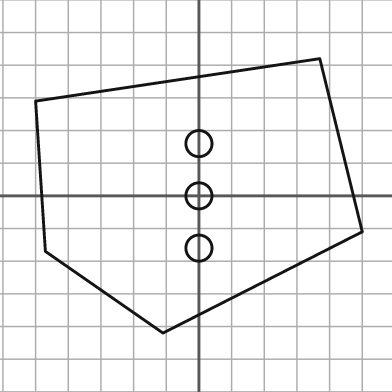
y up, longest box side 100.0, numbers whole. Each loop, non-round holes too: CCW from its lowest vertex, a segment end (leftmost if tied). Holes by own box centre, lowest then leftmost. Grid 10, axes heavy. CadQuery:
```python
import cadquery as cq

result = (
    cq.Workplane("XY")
    .moveTo(-11.0, -42.0)
    .lineTo(50.0, -11.0)
    .lineTo(37.0, 42.0)
    .lineTo(-50.0, 29.0)
    .lineTo(-47.0, -17.0)
    .close()
    .moveTo(0.0, -16.0)
    .circle(4.0)
    .moveTo(0.0, 0.0)
    .circle(4.0)
    .moveTo(0.0, 16.0)
    .circle(4.0)
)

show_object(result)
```